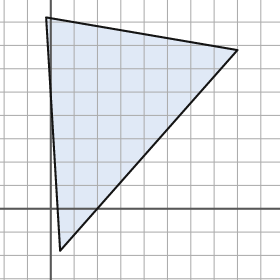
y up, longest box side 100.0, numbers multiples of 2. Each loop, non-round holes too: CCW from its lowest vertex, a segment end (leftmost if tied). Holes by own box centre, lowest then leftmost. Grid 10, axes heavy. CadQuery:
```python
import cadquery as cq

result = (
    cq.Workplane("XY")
    .moveTo(4.0, -18.0)
    .lineTo(80.0, 68.0)
    .lineTo(-2.0, 82.0)
    .close()
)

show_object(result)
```